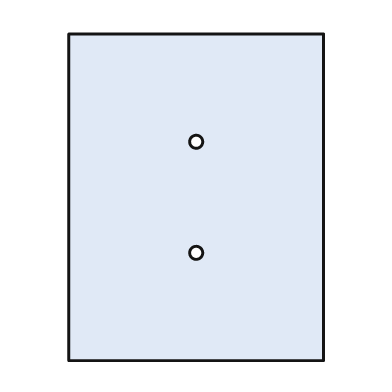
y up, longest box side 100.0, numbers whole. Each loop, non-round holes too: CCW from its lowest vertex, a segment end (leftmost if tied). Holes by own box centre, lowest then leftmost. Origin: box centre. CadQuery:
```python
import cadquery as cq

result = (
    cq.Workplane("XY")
    .moveTo(-39.0, -50.0)
    .lineTo(39.0, -50.0)
    .lineTo(39.0, 50.0)
    .lineTo(-39.0, 50.0)
    .close()
    .moveTo(0.0, -17.0)
    .circle(2.0)
    .moveTo(0.0, 17.0)
    .circle(2.0)
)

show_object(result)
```